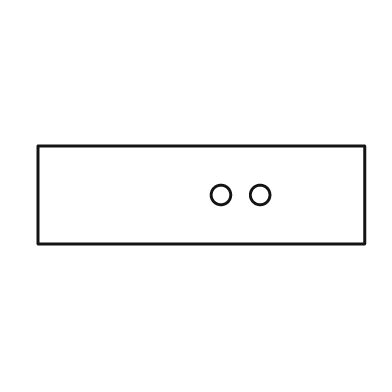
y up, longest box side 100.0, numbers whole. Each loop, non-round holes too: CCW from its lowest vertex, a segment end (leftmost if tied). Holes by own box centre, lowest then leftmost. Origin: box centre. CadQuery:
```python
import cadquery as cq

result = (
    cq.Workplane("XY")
    .moveTo(-50.0, -15.0)
    .lineTo(50.0, -15.0)
    .lineTo(50.0, 15.0)
    .lineTo(-50.0, 15.0)
    .close()
    .moveTo(6.0, 0.0)
    .circle(3.0)
    .moveTo(18.0, 0.0)
    .circle(3.0)
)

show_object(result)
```